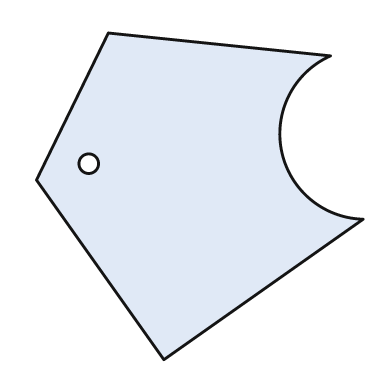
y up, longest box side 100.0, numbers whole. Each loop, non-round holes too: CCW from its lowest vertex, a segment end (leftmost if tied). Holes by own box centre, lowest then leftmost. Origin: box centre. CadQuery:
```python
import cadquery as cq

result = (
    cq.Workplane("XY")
    .moveTo(-11.0, -50.0)
    .lineTo(50.0, -7.0)
    .threePointArc((25.0, 14.0), (40.0, 43.0))
    .lineTo(-28.0, 50.0)
    .lineTo(-50.0, 5.0)
    .close()
    .moveTo(-34.0, 10.0)
    .circle(3.0)
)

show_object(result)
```